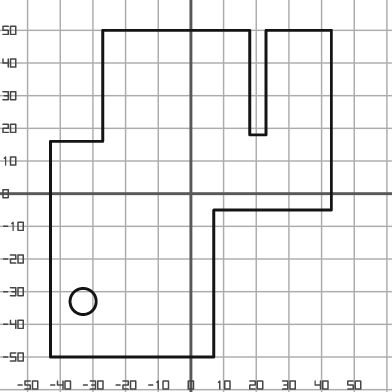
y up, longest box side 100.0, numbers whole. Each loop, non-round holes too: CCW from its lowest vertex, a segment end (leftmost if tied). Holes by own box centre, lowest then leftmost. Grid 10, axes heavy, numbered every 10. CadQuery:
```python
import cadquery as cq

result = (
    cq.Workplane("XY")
    .moveTo(-43.0, -50.0)
    .lineTo(7.0, -50.0)
    .lineTo(7.0, -5.0)
    .lineTo(43.0, -5.0)
    .lineTo(43.0, 50.0)
    .lineTo(23.0, 50.0)
    .lineTo(23.0, 18.0)
    .lineTo(18.0, 18.0)
    .lineTo(18.0, 50.0)
    .lineTo(-27.0, 50.0)
    .lineTo(-27.0, 16.0)
    .lineTo(-43.0, 16.0)
    .close()
    .moveTo(-33.0, -33.0)
    .circle(4.0)
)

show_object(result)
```